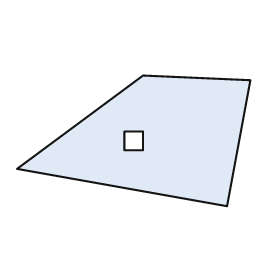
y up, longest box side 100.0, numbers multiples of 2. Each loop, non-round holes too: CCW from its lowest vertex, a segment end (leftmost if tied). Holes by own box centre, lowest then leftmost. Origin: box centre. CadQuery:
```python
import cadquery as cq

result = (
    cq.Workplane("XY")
    .moveTo(40.0, -28.0)
    .lineTo(50.0, 26.0)
    .lineTo(4.0, 28.0)
    .lineTo(-50.0, -12.0)
    .close()
    .moveTo(-4.0, -4.0)
    .lineTo(4.0, -4.0)
    .lineTo(4.0, 4.0)
    .lineTo(-4.0, 4.0)
    .close()
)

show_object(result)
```